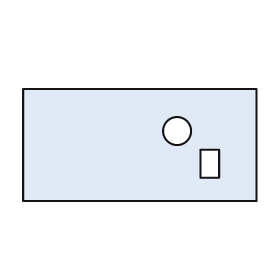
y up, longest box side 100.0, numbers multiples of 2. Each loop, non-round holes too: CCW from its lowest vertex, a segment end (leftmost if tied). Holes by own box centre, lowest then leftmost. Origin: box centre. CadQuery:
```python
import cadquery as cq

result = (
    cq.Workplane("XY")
    .moveTo(-50.0, -24.0)
    .lineTo(50.0, -24.0)
    .lineTo(50.0, 24.0)
    .lineTo(-50.0, 24.0)
    .close()
    .moveTo(26.0, -14.0)
    .lineTo(34.0, -14.0)
    .lineTo(34.0, -2.0)
    .lineTo(26.0, -2.0)
    .close()
    .moveTo(16.0, 6.0)
    .circle(6.0)
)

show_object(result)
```